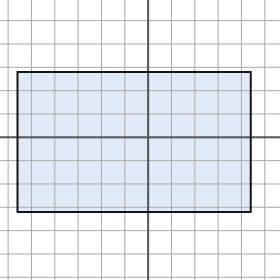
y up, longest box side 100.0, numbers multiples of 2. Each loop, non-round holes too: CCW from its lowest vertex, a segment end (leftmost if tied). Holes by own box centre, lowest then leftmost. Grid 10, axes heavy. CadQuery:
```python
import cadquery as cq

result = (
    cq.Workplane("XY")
    .moveTo(-56.0, -32.0)
    .lineTo(44.0, -32.0)
    .lineTo(44.0, 28.0)
    .lineTo(-56.0, 28.0)
    .close()
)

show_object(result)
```